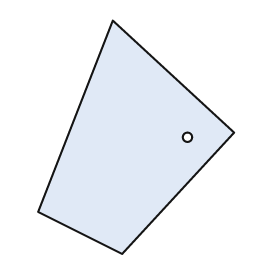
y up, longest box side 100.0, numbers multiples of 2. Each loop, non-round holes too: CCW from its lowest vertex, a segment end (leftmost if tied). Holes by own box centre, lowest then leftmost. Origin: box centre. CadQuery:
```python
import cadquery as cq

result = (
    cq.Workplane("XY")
    .moveTo(-6.0, -50.0)
    .lineTo(42.0, 2.0)
    .lineTo(-10.0, 50.0)
    .lineTo(-42.0, -32.0)
    .close()
    .moveTo(22.0, 0.0)
    .circle(2.0)
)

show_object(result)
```